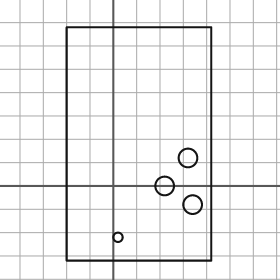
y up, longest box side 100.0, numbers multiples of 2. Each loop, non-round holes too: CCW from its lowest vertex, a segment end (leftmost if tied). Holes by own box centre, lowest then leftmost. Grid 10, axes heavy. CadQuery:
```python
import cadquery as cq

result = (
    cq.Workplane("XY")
    .moveTo(-20.0, -32.0)
    .lineTo(42.0, -32.0)
    .lineTo(42.0, 68.0)
    .lineTo(-20.0, 68.0)
    .close()
    .moveTo(2.0, -22.0)
    .circle(2.0)
    .moveTo(34.0, -8.0)
    .circle(4.0)
    .moveTo(22.0, 0.0)
    .circle(4.0)
    .moveTo(32.0, 12.0)
    .circle(4.0)
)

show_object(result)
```